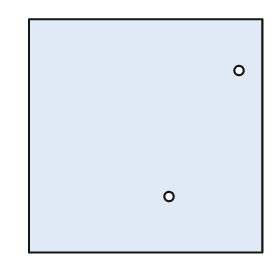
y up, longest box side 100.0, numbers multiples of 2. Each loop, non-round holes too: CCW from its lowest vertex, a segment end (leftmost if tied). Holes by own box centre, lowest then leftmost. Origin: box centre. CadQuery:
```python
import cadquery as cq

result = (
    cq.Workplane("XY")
    .moveTo(-50.0, -50.0)
    .lineTo(50.0, -50.0)
    .lineTo(50.0, 50.0)
    .lineTo(-50.0, 50.0)
    .close()
    .moveTo(10.0, -26.0)
    .circle(2.0)
    .moveTo(40.0, 28.0)
    .circle(2.0)
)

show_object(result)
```